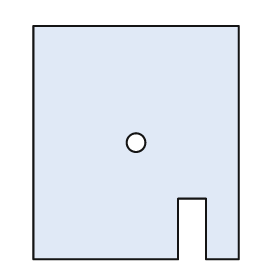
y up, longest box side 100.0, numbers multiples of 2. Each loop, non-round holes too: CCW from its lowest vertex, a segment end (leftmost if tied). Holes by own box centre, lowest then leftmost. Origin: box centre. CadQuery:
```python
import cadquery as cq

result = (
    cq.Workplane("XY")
    .moveTo(-44.0, -50.0)
    .lineTo(18.0, -50.0)
    .lineTo(18.0, -24.0)
    .lineTo(30.0, -24.0)
    .lineTo(30.0, -50.0)
    .lineTo(44.0, -50.0)
    .lineTo(44.0, 50.0)
    .lineTo(-44.0, 50.0)
    .close()
    .moveTo(0.0, 0.0)
    .circle(4.0)
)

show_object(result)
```